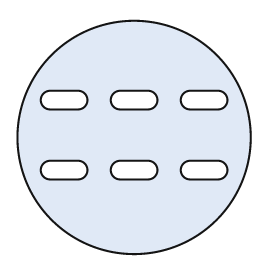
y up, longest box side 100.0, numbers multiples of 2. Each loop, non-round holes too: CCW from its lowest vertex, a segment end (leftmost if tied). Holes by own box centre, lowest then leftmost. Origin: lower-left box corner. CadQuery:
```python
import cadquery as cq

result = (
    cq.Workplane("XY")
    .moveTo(50.0, 50.0)
    .circle(50.0)
    .moveTo(14.0, 32.0)
    .lineTo(26.0, 32.0)
    .threePointArc((30.0, 36.0), (26.0, 40.0))
    .lineTo(14.0, 40.0)
    .threePointArc((10.0, 36.0), (14.0, 32.0))
    .close()
    .moveTo(44.0, 32.0)
    .lineTo(56.0, 32.0)
    .threePointArc((60.0, 36.0), (56.0, 40.0))
    .lineTo(44.0, 40.0)
    .threePointArc((40.0, 36.0), (44.0, 32.0))
    .close()
    .moveTo(74.0, 32.0)
    .lineTo(86.0, 32.0)
    .threePointArc((90.0, 36.0), (86.0, 40.0))
    .lineTo(74.0, 40.0)
    .threePointArc((70.0, 36.0), (74.0, 32.0))
    .close()
    .moveTo(14.0, 62.0)
    .lineTo(26.0, 62.0)
    .threePointArc((30.0, 66.0), (26.0, 70.0))
    .lineTo(14.0, 70.0)
    .threePointArc((10.0, 66.0), (14.0, 62.0))
    .close()
    .moveTo(44.0, 62.0)
    .lineTo(56.0, 62.0)
    .threePointArc((60.0, 66.0), (56.0, 70.0))
    .lineTo(44.0, 70.0)
    .threePointArc((40.0, 66.0), (44.0, 62.0))
    .close()
    .moveTo(74.0, 62.0)
    .lineTo(86.0, 62.0)
    .threePointArc((90.0, 66.0), (86.0, 70.0))
    .lineTo(74.0, 70.0)
    .threePointArc((70.0, 66.0), (74.0, 62.0))
    .close()
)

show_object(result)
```